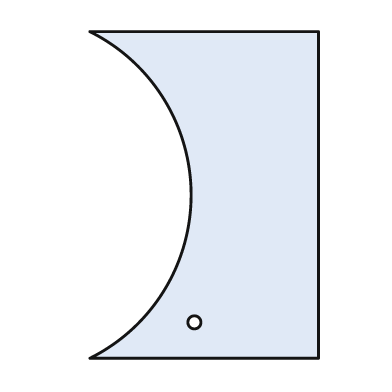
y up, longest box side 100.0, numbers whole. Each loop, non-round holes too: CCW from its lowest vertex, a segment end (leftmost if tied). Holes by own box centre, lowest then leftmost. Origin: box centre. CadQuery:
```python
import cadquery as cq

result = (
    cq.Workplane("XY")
    .moveTo(-35.0, -50.0)
    .lineTo(35.0, -50.0)
    .lineTo(35.0, 50.0)
    .lineTo(-35.0, 50.0)
    .threePointArc((-4.0, 0.0), (-35.0, -50.0))
    .close()
    .moveTo(-3.0, -39.0)
    .circle(2.0)
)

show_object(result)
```